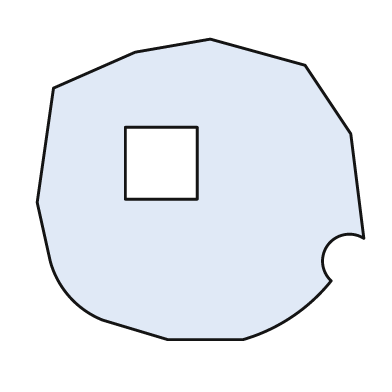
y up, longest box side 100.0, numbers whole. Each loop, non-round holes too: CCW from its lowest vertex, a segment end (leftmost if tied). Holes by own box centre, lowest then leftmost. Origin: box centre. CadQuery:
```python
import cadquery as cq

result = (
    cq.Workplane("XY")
    .moveTo(-10.0, -46.0)
    .lineTo(13.0, -46.0)
    .threePointArc((28.0, -39.0), (40.0, -28.0))
    .threePointArc((39.0, -17.0), (50.0, -15.0))
    .lineTo(46.0, 17.0)
    .lineTo(32.0, 38.0)
    .lineTo(3.0, 46.0)
    .lineTo(-20.0, 42.0)
    .lineTo(-45.0, 31.0)
    .lineTo(-50.0, -4.0)
    .lineTo(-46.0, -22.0)
    .threePointArc((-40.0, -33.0), (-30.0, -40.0))
    .close()
    .moveTo(-23.0, -3.0)
    .lineTo(-1.0, -3.0)
    .lineTo(-1.0, 19.0)
    .lineTo(-23.0, 19.0)
    .close()
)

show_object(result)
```